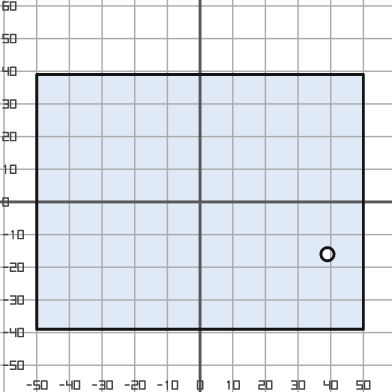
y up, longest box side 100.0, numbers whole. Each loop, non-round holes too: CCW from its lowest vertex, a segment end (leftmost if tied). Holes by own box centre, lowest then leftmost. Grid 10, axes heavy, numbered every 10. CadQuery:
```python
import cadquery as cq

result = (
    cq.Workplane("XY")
    .moveTo(-50.0, -39.0)
    .lineTo(50.0, -39.0)
    .lineTo(50.0, 39.0)
    .lineTo(-50.0, 39.0)
    .close()
    .moveTo(39.0, -16.0)
    .circle(2.0)
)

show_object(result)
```